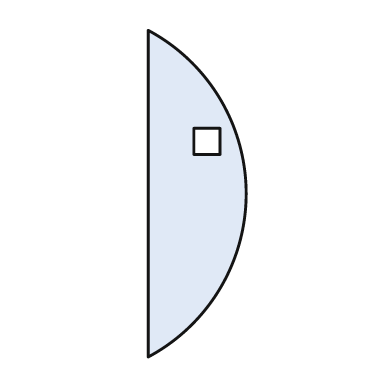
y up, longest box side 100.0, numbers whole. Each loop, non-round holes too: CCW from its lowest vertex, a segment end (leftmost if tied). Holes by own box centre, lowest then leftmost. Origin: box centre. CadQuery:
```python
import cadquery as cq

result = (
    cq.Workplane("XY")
    .moveTo(-15.0, -50.0)
    .threePointArc((15.0, 0.0), (-15.0, 50.0))
    .close()
    .moveTo(-1.0, 12.0)
    .lineTo(7.0, 12.0)
    .lineTo(7.0, 20.0)
    .lineTo(-1.0, 20.0)
    .close()
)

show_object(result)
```